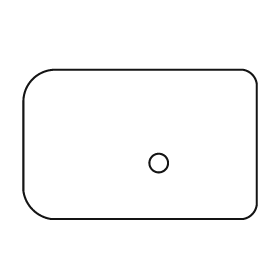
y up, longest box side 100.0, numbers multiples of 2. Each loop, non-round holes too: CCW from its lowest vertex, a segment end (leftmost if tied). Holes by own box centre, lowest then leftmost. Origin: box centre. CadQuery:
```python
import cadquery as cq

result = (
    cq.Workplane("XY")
    .moveTo(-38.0, -32.0)
    .lineTo(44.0, -32.0)
    .threePointArc((48.0, -30.0), (50.0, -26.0))
    .lineTo(50.0, 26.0)
    .threePointArc((48.0, 30.0), (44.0, 32.0))
    .lineTo(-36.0, 32.0)
    .threePointArc((-46.0, 28.0), (-50.0, 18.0))
    .lineTo(-50.0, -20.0)
    .threePointArc((-46.0, -28.0), (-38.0, -32.0))
    .close()
    .moveTo(8.0, -8.0)
    .circle(4.0)
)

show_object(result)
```